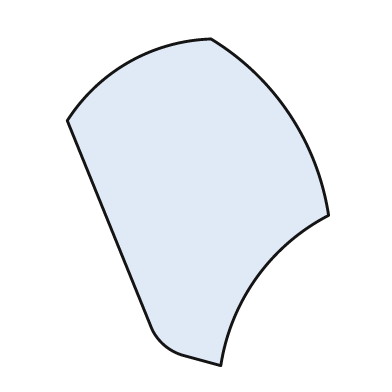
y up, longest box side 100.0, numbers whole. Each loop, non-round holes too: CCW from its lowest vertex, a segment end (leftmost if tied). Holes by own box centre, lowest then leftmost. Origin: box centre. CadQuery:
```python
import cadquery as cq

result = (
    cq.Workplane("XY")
    .moveTo(7.0, -50.0)
    .threePointArc((18.0, -23.0), (40.0, -4.0))
    .threePointArc((28.0, 27.0), (4.0, 50.0))
    .threePointArc((-21.0, 43.0), (-40.0, 25.0))
    .lineTo(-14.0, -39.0)
    .threePointArc((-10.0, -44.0), (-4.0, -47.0))
    .close()
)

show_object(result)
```